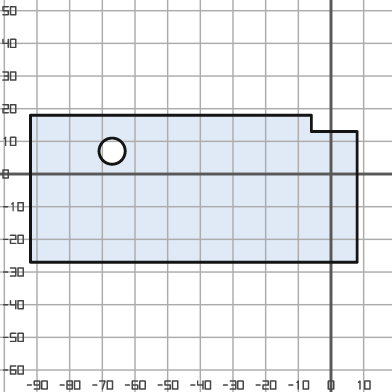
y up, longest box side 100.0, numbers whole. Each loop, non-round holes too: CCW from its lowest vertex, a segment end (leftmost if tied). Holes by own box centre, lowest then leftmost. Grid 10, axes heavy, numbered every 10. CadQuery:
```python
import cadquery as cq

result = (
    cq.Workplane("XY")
    .moveTo(-92.0, -27.0)
    .lineTo(8.0, -27.0)
    .lineTo(8.0, 13.0)
    .lineTo(-6.0, 13.0)
    .lineTo(-6.0, 18.0)
    .lineTo(-92.0, 18.0)
    .close()
    .moveTo(-67.0, 7.0)
    .circle(4.0)
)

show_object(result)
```